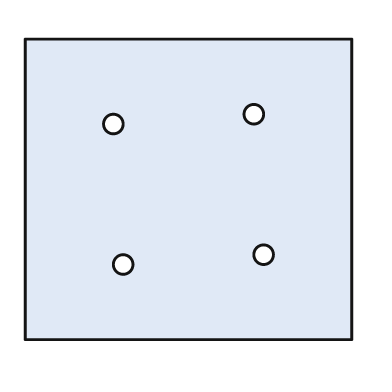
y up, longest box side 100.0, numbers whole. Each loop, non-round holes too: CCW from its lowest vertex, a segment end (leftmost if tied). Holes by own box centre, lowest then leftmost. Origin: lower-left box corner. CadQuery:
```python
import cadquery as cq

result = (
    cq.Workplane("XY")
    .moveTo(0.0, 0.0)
    .lineTo(100.0, 0.0)
    .lineTo(100.0, 92.0)
    .lineTo(0.0, 92.0)
    .close()
    .moveTo(30.0, 23.0)
    .circle(3.0)
    .moveTo(73.0, 26.0)
    .circle(3.0)
    .moveTo(27.0, 66.0)
    .circle(3.0)
    .moveTo(70.0, 69.0)
    .circle(3.0)
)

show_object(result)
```